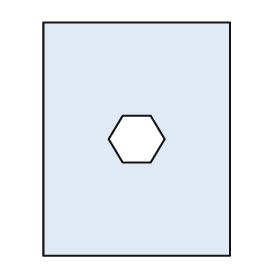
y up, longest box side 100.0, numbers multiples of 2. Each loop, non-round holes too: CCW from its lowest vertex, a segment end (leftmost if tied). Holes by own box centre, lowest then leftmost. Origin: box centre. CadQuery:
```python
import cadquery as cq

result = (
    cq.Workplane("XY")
    .moveTo(-40.0, -50.0)
    .lineTo(40.0, -50.0)
    .lineTo(40.0, 50.0)
    .lineTo(-40.0, 50.0)
    .close()
    .moveTo(-6.0, -10.0)
    .lineTo(6.0, -10.0)
    .lineTo(12.0, 0.0)
    .lineTo(6.0, 10.0)
    .lineTo(-6.0, 10.0)
    .lineTo(-12.0, 0.0)
    .close()
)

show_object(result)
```